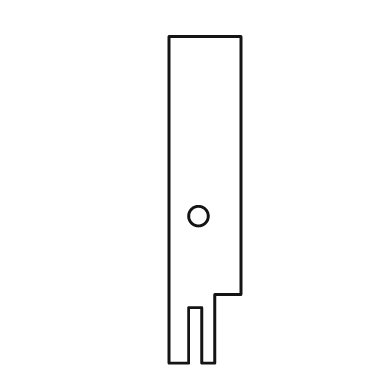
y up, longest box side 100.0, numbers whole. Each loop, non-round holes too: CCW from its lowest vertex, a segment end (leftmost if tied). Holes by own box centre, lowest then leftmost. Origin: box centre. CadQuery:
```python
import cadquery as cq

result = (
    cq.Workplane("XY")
    .moveTo(-11.0, -50.0)
    .lineTo(-5.0, -50.0)
    .lineTo(-5.0, -33.0)
    .lineTo(-1.0, -33.0)
    .lineTo(-1.0, -50.0)
    .lineTo(3.0, -50.0)
    .lineTo(3.0, -29.0)
    .lineTo(11.0, -29.0)
    .lineTo(11.0, 50.0)
    .lineTo(-11.0, 50.0)
    .close()
    .moveTo(-2.0, -5.0)
    .circle(3.0)
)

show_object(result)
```